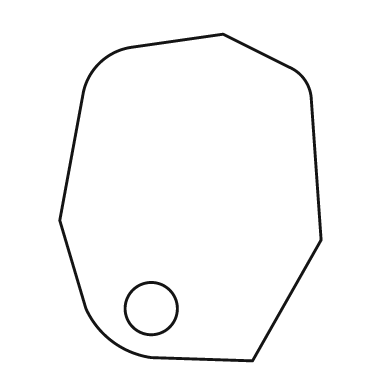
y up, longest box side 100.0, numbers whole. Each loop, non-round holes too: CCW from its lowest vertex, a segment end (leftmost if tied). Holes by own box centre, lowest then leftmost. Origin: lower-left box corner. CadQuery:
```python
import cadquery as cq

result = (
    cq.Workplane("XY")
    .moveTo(59.0, 0.0)
    .lineTo(80.0, 37.0)
    .lineTo(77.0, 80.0)
    .threePointArc((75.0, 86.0), (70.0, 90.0))
    .lineTo(50.0, 100.0)
    .lineTo(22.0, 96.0)
    .threePointArc((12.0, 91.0), (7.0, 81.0))
    .lineTo(0.0, 43.0)
    .lineTo(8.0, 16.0)
    .threePointArc((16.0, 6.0), (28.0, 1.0))
    .close()
    .moveTo(28.0, 16.0)
    .circle(8.0)
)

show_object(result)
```